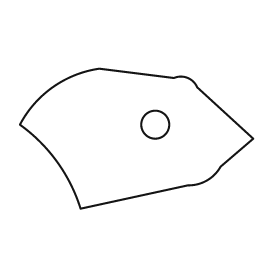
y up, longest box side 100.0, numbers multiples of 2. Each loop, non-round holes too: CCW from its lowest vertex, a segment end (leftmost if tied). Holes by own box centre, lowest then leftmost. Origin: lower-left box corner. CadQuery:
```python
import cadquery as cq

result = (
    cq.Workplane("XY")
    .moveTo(26.0, 0.0)
    .lineTo(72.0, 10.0)
    .threePointArc((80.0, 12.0), (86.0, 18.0))
    .lineTo(100.0, 30.0)
    .lineTo(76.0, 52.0)
    .threePointArc((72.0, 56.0), (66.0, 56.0))
    .lineTo(34.0, 60.0)
    .threePointArc((14.0, 52.0), (0.0, 36.0))
    .threePointArc((16.0, 20.0), (26.0, 0.0))
    .close()
    .moveTo(58.0, 36.0)
    .circle(6.0)
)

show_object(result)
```